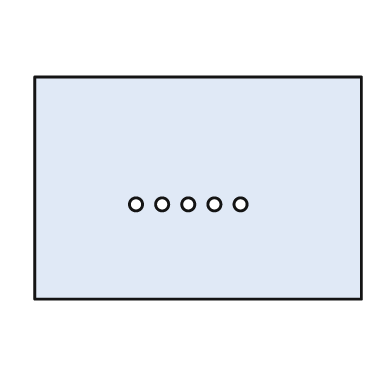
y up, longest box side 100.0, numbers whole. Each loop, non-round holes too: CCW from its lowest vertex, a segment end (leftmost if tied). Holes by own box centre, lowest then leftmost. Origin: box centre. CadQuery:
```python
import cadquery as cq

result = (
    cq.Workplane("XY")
    .moveTo(-50.0, -34.0)
    .lineTo(50.0, -34.0)
    .lineTo(50.0, 34.0)
    .lineTo(-50.0, 34.0)
    .close()
    .moveTo(-19.0, -5.0)
    .circle(2.0)
    .moveTo(-11.0, -5.0)
    .circle(2.0)
    .moveTo(-3.0, -5.0)
    .circle(2.0)
    .moveTo(5.0, -5.0)
    .circle(2.0)
    .moveTo(13.0, -5.0)
    .circle(2.0)
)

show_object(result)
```